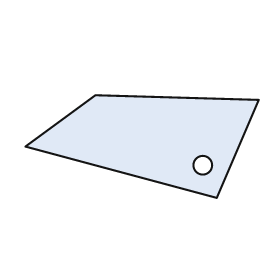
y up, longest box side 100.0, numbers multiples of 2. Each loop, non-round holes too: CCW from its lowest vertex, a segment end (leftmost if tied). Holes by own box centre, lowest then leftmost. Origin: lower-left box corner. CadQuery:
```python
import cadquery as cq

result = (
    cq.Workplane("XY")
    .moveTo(82.0, 0.0)
    .lineTo(100.0, 42.0)
    .lineTo(30.0, 44.0)
    .lineTo(0.0, 22.0)
    .close()
    .moveTo(76.0, 14.0)
    .circle(4.0)
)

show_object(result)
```